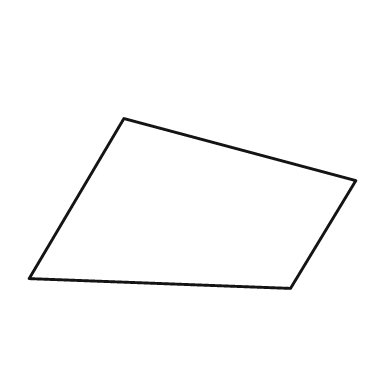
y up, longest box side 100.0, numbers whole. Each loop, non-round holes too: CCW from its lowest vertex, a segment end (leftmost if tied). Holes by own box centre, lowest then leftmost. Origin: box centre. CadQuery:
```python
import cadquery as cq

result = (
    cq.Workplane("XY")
    .moveTo(30.0, -26.0)
    .lineTo(50.0, 7.0)
    .lineTo(-21.0, 26.0)
    .lineTo(-50.0, -23.0)
    .close()
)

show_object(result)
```